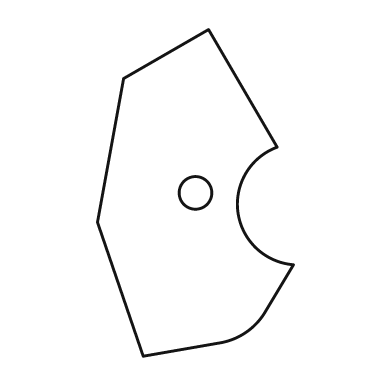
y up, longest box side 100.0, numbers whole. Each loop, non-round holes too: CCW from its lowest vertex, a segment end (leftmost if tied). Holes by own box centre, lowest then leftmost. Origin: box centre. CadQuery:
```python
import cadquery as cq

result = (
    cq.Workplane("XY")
    .moveTo(-16.0, -50.0)
    .lineTo(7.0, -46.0)
    .threePointArc((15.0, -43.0), (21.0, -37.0))
    .lineTo(30.0, -22.0)
    .threePointArc((13.0, -6.0), (25.0, 14.0))
    .lineTo(4.0, 50.0)
    .lineTo(-22.0, 35.0)
    .lineTo(-30.0, -9.0)
    .close()
    .moveTo(0.0, 0.0)
    .circle(5.0)
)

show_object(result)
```